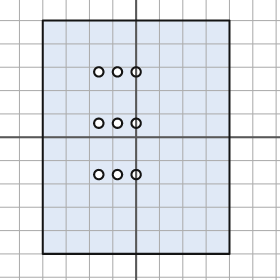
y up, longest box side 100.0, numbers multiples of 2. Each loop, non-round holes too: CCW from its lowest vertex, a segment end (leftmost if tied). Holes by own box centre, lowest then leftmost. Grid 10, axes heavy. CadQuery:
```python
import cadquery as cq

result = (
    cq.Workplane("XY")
    .moveTo(-40.0, -50.0)
    .lineTo(40.0, -50.0)
    .lineTo(40.0, 50.0)
    .lineTo(-40.0, 50.0)
    .close()
    .moveTo(-16.0, -16.0)
    .circle(2.0)
    .moveTo(-8.0, -16.0)
    .circle(2.0)
    .moveTo(0.0, -16.0)
    .circle(2.0)
    .moveTo(-16.0, 6.0)
    .circle(2.0)
    .moveTo(-8.0, 6.0)
    .circle(2.0)
    .moveTo(0.0, 6.0)
    .circle(2.0)
    .moveTo(-16.0, 28.0)
    .circle(2.0)
    .moveTo(-8.0, 28.0)
    .circle(2.0)
    .moveTo(0.0, 28.0)
    .circle(2.0)
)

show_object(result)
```